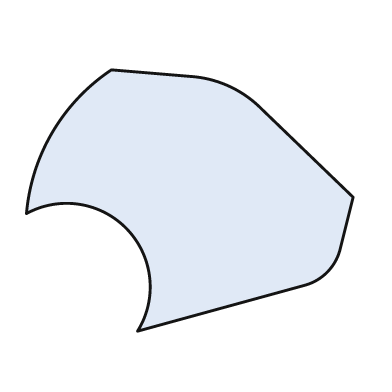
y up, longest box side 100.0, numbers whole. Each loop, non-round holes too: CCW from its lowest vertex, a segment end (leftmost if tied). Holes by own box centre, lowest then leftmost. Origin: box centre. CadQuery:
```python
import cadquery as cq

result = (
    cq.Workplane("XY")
    .moveTo(-16.0, -40.0)
    .lineTo(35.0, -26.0)
    .threePointArc((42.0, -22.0), (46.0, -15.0))
    .lineTo(50.0, 1.0)
    .lineTo(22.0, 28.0)
    .threePointArc((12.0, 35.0), (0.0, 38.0))
    .lineTo(-24.0, 40.0)
    .threePointArc((-42.0, 21.0), (-50.0, -4.0))
    .threePointArc((-19.0, -9.0), (-16.0, -40.0))
    .close()
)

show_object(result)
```